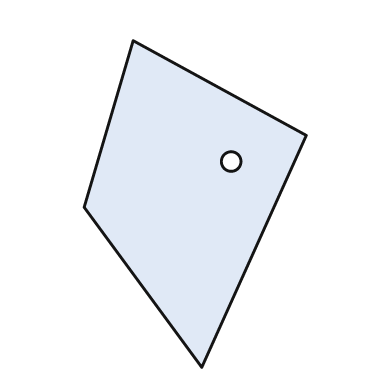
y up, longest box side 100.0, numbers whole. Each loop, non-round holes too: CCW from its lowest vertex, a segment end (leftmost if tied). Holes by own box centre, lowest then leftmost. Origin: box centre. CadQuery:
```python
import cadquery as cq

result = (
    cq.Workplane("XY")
    .moveTo(2.0, -50.0)
    .lineTo(34.0, 21.0)
    .lineTo(-19.0, 50.0)
    .lineTo(-34.0, -1.0)
    .close()
    .moveTo(11.0, 13.0)
    .circle(3.0)
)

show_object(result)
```